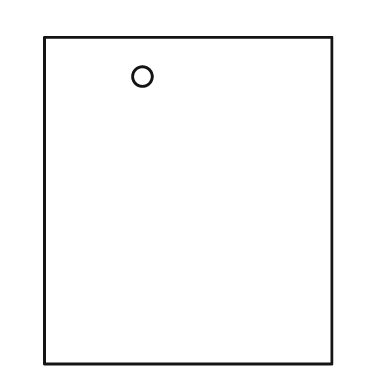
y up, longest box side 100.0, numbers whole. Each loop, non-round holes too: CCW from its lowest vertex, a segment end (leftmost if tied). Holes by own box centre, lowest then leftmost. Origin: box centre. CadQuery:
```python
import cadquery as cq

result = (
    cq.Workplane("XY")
    .moveTo(-44.0, -50.0)
    .lineTo(44.0, -50.0)
    .lineTo(44.0, 50.0)
    .lineTo(-44.0, 50.0)
    .close()
    .moveTo(-14.0, 38.0)
    .circle(3.0)
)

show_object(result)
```